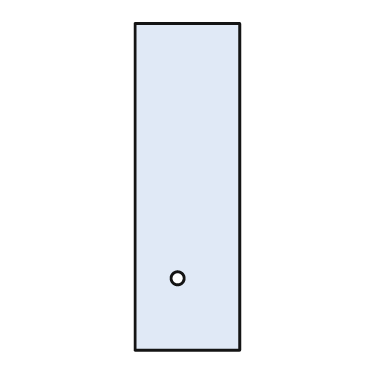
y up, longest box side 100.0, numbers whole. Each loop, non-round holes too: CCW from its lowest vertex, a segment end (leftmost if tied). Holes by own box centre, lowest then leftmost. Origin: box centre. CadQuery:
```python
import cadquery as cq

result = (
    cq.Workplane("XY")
    .moveTo(-16.0, -50.0)
    .lineTo(16.0, -50.0)
    .lineTo(16.0, 50.0)
    .lineTo(-16.0, 50.0)
    .close()
    .moveTo(-3.0, -28.0)
    .circle(2.0)
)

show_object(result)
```